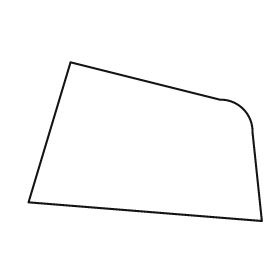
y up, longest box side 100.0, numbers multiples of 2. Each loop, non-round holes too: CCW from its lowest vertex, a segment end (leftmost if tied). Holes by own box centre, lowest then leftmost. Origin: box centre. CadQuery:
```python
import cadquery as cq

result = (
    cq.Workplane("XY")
    .moveTo(50.0, -34.0)
    .lineTo(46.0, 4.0)
    .threePointArc((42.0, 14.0), (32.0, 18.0))
    .lineTo(-32.0, 34.0)
    .lineTo(-50.0, -26.0)
    .close()
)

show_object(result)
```